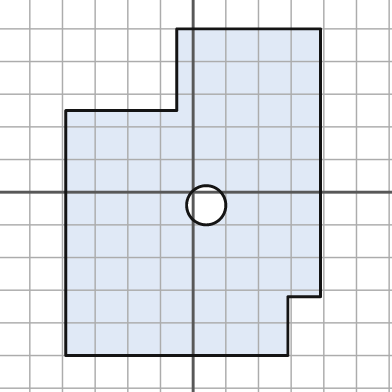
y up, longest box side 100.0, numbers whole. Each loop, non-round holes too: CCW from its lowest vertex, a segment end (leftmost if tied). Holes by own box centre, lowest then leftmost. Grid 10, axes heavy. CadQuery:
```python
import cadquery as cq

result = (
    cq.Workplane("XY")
    .moveTo(-39.0, -50.0)
    .lineTo(29.0, -50.0)
    .lineTo(29.0, -32.0)
    .lineTo(39.0, -32.0)
    .lineTo(39.0, 50.0)
    .lineTo(-5.0, 50.0)
    .lineTo(-5.0, 25.0)
    .lineTo(-39.0, 25.0)
    .close()
    .moveTo(4.0, -4.0)
    .circle(6.0)
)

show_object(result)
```